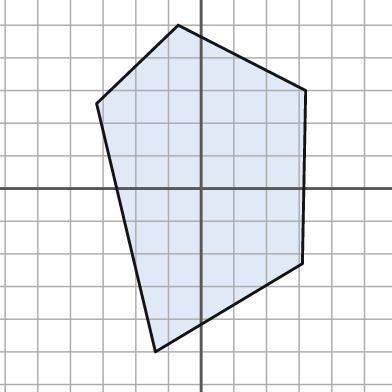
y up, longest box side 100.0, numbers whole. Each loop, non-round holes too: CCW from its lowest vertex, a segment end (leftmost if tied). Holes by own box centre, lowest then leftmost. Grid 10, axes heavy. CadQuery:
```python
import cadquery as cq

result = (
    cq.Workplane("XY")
    .moveTo(-14.0, -50.0)
    .lineTo(31.0, -23.0)
    .lineTo(32.0, 30.0)
    .lineTo(-7.0, 50.0)
    .lineTo(-32.0, 26.0)
    .close()
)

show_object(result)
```